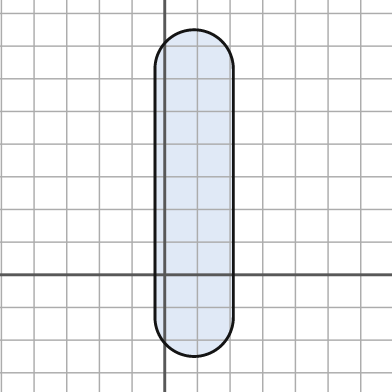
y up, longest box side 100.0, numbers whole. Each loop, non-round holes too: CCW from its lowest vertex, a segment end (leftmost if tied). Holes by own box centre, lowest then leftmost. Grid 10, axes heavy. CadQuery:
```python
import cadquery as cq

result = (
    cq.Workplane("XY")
    .moveTo(-3.0, -13.0)
    .threePointArc((9.0, -25.0), (21.0, -13.0))
    .lineTo(21.0, 63.0)
    .threePointArc((9.0, 75.0), (-3.0, 63.0))
    .close()
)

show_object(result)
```